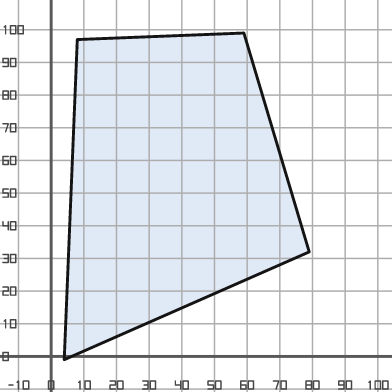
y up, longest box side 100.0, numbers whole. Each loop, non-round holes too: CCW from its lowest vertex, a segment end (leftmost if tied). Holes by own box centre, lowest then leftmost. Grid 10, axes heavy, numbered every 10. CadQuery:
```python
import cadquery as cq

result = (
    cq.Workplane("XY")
    .moveTo(4.0, -1.0)
    .lineTo(79.0, 32.0)
    .lineTo(59.0, 99.0)
    .lineTo(8.0, 97.0)
    .close()
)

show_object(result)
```